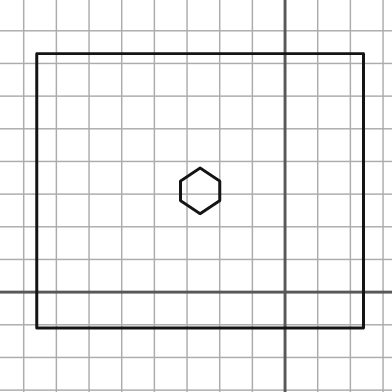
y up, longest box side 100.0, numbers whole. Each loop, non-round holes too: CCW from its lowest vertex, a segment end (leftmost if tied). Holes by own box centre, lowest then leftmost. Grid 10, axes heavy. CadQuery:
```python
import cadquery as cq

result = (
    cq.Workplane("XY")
    .moveTo(-76.0, -11.0)
    .lineTo(24.0, -11.0)
    .lineTo(24.0, 73.0)
    .lineTo(-76.0, 73.0)
    .close()
    .moveTo(-26.0, 24.0)
    .lineTo(-20.0, 28.0)
    .lineTo(-20.0, 34.0)
    .lineTo(-26.0, 38.0)
    .lineTo(-32.0, 34.0)
    .lineTo(-32.0, 28.0)
    .close()
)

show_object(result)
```